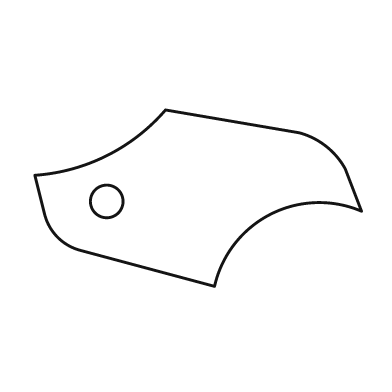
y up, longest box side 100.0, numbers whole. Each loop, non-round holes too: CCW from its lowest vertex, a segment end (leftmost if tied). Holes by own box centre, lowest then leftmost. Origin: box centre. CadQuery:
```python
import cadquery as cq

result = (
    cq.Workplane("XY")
    .moveTo(5.0, -27.0)
    .threePointArc((22.0, -5.0), (50.0, -4.0))
    .lineTo(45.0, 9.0)
    .threePointArc((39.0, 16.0), (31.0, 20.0))
    .lineTo(-10.0, 27.0)
    .threePointArc((-28.0, 13.0), (-50.0, 7.0))
    .lineTo(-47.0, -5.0)
    .threePointArc((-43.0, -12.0), (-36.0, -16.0))
    .close()
    .moveTo(-28.0, -1.0)
    .circle(5.0)
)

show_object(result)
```